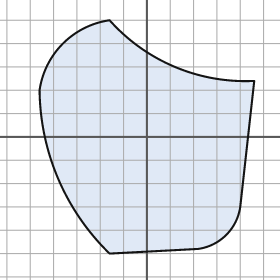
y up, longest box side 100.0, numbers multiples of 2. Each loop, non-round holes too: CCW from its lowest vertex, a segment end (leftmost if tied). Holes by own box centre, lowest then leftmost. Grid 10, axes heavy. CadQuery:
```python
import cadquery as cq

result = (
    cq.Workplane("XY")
    .moveTo(-16.0, -50.0)
    .lineTo(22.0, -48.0)
    .threePointArc((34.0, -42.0), (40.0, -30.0))
    .lineTo(46.0, 24.0)
    .threePointArc((12.0, 30.0), (-16.0, 50.0))
    .threePointArc((-36.0, 40.0), (-46.0, 20.0))
    .threePointArc((-38.0, -18.0), (-16.0, -50.0))
    .close()
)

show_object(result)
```